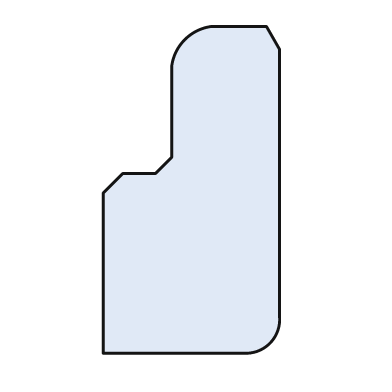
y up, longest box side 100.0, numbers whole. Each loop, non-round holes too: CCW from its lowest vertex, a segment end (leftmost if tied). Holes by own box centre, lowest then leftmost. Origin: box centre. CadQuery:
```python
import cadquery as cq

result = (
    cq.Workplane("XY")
    .moveTo(-27.0, -50.0)
    .lineTo(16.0, -50.0)
    .threePointArc((24.0, -47.0), (27.0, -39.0))
    .lineTo(27.0, 43.0)
    .lineTo(23.0, 50.0)
    .lineTo(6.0, 50.0)
    .threePointArc((-2.0, 46.0), (-6.0, 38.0))
    .lineTo(-6.0, 10.0)
    .lineTo(-11.0, 5.0)
    .lineTo(-21.0, 5.0)
    .lineTo(-27.0, -1.0)
    .close()
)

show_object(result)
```